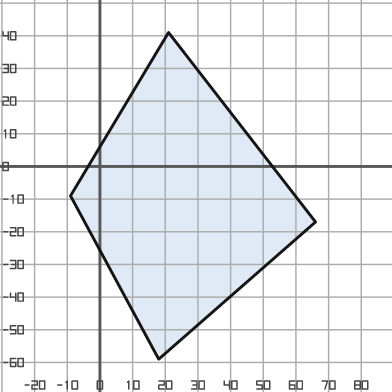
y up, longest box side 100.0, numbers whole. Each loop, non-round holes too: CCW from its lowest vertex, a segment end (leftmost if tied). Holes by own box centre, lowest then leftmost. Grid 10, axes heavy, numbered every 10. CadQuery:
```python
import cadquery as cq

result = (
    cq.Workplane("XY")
    .moveTo(18.0, -59.0)
    .lineTo(66.0, -17.0)
    .lineTo(21.0, 41.0)
    .lineTo(-9.0, -9.0)
    .close()
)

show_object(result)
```